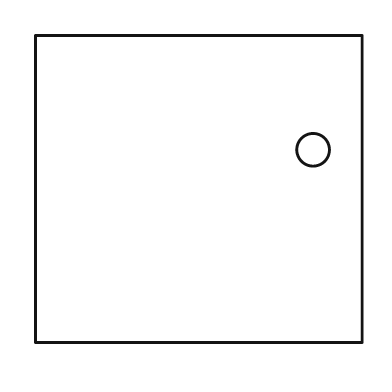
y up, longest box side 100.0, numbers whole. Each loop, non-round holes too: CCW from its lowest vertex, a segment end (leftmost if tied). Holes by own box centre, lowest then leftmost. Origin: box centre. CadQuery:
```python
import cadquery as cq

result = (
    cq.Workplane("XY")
    .moveTo(-50.0, -47.0)
    .lineTo(50.0, -47.0)
    .lineTo(50.0, 47.0)
    .lineTo(-50.0, 47.0)
    .close()
    .moveTo(35.0, 12.0)
    .circle(5.0)
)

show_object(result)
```